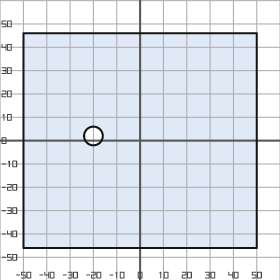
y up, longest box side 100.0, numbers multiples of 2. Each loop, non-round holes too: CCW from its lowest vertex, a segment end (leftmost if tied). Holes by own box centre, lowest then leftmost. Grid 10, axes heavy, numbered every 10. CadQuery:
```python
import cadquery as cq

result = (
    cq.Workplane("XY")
    .moveTo(-50.0, -46.0)
    .lineTo(50.0, -46.0)
    .lineTo(50.0, 46.0)
    .lineTo(-50.0, 46.0)
    .close()
    .moveTo(-20.0, 2.0)
    .circle(4.0)
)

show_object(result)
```